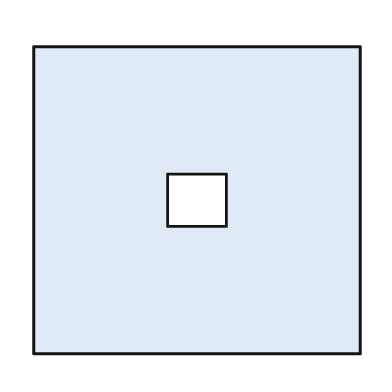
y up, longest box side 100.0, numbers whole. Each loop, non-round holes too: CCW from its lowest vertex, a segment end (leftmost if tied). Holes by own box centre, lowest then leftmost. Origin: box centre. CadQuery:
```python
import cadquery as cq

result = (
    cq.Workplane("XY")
    .moveTo(-50.0, -47.0)
    .lineTo(50.0, -47.0)
    .lineTo(50.0, 47.0)
    .lineTo(-50.0, 47.0)
    .close()
    .moveTo(-9.0, -8.0)
    .lineTo(9.0, -8.0)
    .lineTo(9.0, 8.0)
    .lineTo(-9.0, 8.0)
    .close()
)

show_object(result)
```